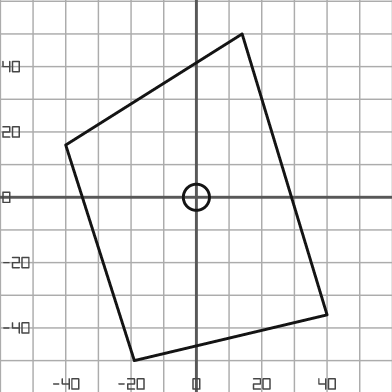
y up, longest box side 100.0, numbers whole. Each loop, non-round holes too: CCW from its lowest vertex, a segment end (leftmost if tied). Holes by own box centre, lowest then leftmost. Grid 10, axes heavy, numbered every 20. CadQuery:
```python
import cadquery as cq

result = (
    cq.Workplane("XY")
    .moveTo(-19.0, -50.0)
    .lineTo(40.0, -36.0)
    .lineTo(14.0, 50.0)
    .lineTo(-40.0, 16.0)
    .close()
    .moveTo(0.0, 0.0)
    .circle(4.0)
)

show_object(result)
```